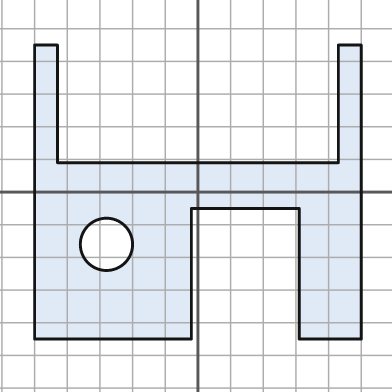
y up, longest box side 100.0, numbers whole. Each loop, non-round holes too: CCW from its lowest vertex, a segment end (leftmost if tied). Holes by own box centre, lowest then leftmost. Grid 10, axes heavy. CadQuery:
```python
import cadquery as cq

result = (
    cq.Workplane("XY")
    .moveTo(-50.0, -45.0)
    .lineTo(-2.0, -45.0)
    .lineTo(-2.0, -5.0)
    .lineTo(31.0, -5.0)
    .lineTo(31.0, -45.0)
    .lineTo(50.0, -45.0)
    .lineTo(50.0, 45.0)
    .lineTo(43.0, 45.0)
    .lineTo(43.0, 9.0)
    .lineTo(-43.0, 9.0)
    .lineTo(-43.0, 45.0)
    .lineTo(-50.0, 45.0)
    .close()
    .moveTo(-28.0, -16.0)
    .circle(8.0)
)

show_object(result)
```